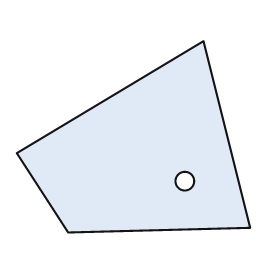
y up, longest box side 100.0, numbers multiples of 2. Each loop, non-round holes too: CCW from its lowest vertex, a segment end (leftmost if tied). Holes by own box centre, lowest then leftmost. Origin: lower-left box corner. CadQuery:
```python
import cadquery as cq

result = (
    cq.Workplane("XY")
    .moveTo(22.0, 0.0)
    .lineTo(100.0, 2.0)
    .lineTo(80.0, 82.0)
    .lineTo(0.0, 34.0)
    .close()
    .moveTo(72.0, 22.0)
    .circle(4.0)
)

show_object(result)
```